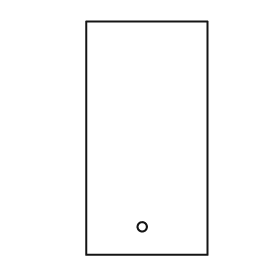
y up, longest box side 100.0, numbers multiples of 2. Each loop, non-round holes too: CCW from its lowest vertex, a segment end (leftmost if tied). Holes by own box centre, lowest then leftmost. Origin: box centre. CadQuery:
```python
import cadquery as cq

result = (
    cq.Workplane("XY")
    .moveTo(-26.0, -50.0)
    .lineTo(26.0, -50.0)
    .lineTo(26.0, 50.0)
    .lineTo(-26.0, 50.0)
    .close()
    .moveTo(-2.0, -38.0)
    .circle(2.0)
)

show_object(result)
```